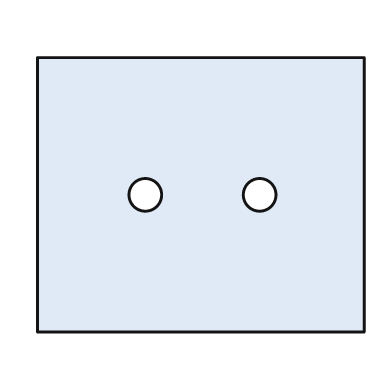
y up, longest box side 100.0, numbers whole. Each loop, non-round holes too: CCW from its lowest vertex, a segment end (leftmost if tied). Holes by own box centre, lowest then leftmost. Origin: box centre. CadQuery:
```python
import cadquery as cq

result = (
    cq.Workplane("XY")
    .moveTo(-50.0, -42.0)
    .lineTo(50.0, -42.0)
    .lineTo(50.0, 42.0)
    .lineTo(-50.0, 42.0)
    .close()
    .moveTo(-17.0, 0.0)
    .circle(5.0)
    .moveTo(18.0, 0.0)
    .circle(5.0)
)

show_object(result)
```